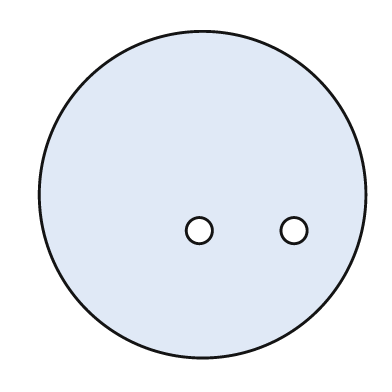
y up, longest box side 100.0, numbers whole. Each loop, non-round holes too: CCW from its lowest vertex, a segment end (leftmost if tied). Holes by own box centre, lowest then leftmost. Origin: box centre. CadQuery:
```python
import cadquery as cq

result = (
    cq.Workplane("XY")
    .moveTo(0.0, 0.0)
    .circle(50.0)
    .moveTo(-1.0, -11.0)
    .circle(4.0)
    .moveTo(28.0, -11.0)
    .circle(4.0)
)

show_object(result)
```